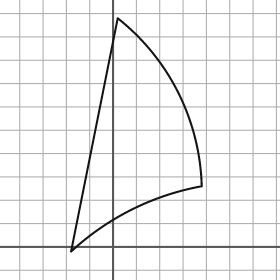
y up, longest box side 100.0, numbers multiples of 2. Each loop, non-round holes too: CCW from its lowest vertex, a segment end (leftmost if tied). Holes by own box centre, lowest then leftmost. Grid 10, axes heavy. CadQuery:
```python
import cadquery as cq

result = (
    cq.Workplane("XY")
    .moveTo(-18.0, -2.0)
    .threePointArc((8.0, 16.0), (38.0, 26.0))
    .threePointArc((28.0, 66.0), (2.0, 98.0))
    .close()
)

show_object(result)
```